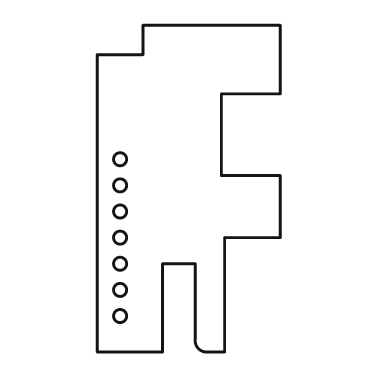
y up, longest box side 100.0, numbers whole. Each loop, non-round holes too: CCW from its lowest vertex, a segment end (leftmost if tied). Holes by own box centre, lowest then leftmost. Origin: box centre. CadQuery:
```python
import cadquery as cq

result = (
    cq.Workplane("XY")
    .moveTo(-28.0, -50.0)
    .lineTo(-8.0, -50.0)
    .lineTo(-8.0, -23.0)
    .lineTo(2.0, -23.0)
    .lineTo(2.0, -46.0)
    .threePointArc((3.0, -49.0), (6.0, -50.0))
    .lineTo(11.0, -50.0)
    .lineTo(11.0, -15.0)
    .lineTo(28.0, -15.0)
    .lineTo(28.0, 4.0)
    .lineTo(10.0, 4.0)
    .lineTo(10.0, 29.0)
    .lineTo(28.0, 29.0)
    .lineTo(28.0, 50.0)
    .lineTo(-14.0, 50.0)
    .lineTo(-14.0, 41.0)
    .lineTo(-28.0, 41.0)
    .close()
    .moveTo(-21.0, -39.0)
    .circle(2.0)
    .moveTo(-21.0, -31.0)
    .circle(2.0)
    .moveTo(-21.0, -23.0)
    .circle(2.0)
    .moveTo(-21.0, -15.0)
    .circle(2.0)
    .moveTo(-21.0, -7.0)
    .circle(2.0)
    .moveTo(-21.0, 1.0)
    .circle(2.0)
    .moveTo(-21.0, 9.0)
    .circle(2.0)
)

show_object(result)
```